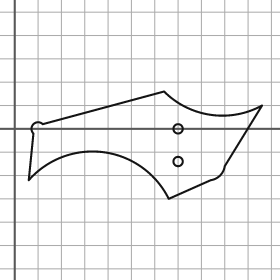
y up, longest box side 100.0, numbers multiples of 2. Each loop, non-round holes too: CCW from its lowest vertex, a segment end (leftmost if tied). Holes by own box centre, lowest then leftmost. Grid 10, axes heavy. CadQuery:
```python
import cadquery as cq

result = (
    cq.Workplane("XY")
    .moveTo(66.0, -30.0)
    .lineTo(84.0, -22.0)
    .threePointArc((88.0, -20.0), (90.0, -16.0))
    .lineTo(106.0, 10.0)
    .threePointArc((84.0, 6.0), (64.0, 16.0))
    .lineTo(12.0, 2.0)
    .threePointArc((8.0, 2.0), (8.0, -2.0))
    .lineTo(6.0, -22.0)
    .threePointArc((38.0, -10.0), (66.0, -30.0))
    .close()
    .moveTo(70.0, -14.0)
    .circle(2.0)
    .moveTo(70.0, 0.0)
    .circle(2.0)
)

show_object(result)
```